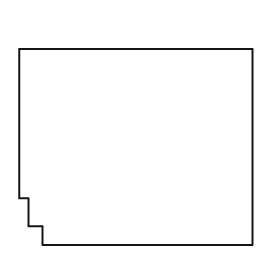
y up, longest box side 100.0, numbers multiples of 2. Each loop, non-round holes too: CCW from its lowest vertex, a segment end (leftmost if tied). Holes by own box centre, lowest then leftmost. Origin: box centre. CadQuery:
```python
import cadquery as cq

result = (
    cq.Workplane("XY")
    .moveTo(-40.0, -42.0)
    .lineTo(50.0, -42.0)
    .lineTo(50.0, 42.0)
    .lineTo(-50.0, 42.0)
    .lineTo(-50.0, -22.0)
    .lineTo(-46.0, -22.0)
    .lineTo(-46.0, -34.0)
    .lineTo(-40.0, -34.0)
    .close()
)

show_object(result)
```